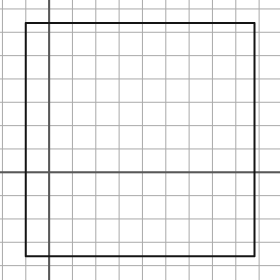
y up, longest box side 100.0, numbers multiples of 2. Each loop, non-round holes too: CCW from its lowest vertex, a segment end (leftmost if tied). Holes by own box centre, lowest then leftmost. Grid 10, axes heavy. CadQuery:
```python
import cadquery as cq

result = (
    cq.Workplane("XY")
    .moveTo(-10.0, -36.0)
    .lineTo(88.0, -36.0)
    .lineTo(88.0, 64.0)
    .lineTo(-10.0, 64.0)
    .close()
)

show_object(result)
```